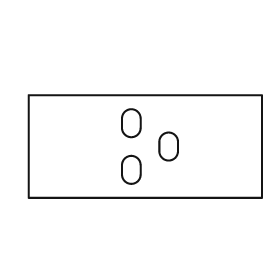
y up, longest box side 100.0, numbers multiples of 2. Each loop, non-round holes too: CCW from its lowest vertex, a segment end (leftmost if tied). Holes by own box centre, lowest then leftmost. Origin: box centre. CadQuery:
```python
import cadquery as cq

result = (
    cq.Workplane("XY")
    .moveTo(-50.0, -22.0)
    .lineTo(50.0, -22.0)
    .lineTo(50.0, 22.0)
    .lineTo(-50.0, 22.0)
    .close()
    .moveTo(-10.0, -12.0)
    .threePointArc((-6.0, -16.0), (-2.0, -12.0))
    .lineTo(-2.0, -8.0)
    .threePointArc((-6.0, -4.0), (-10.0, -8.0))
    .close()
    .moveTo(6.0, -2.0)
    .threePointArc((10.0, -6.0), (14.0, -2.0))
    .lineTo(14.0, 2.0)
    .threePointArc((10.0, 6.0), (6.0, 2.0))
    .close()
    .moveTo(-10.0, 8.0)
    .threePointArc((-6.0, 4.0), (-2.0, 8.0))
    .lineTo(-2.0, 12.0)
    .threePointArc((-6.0, 16.0), (-10.0, 12.0))
    .close()
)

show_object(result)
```